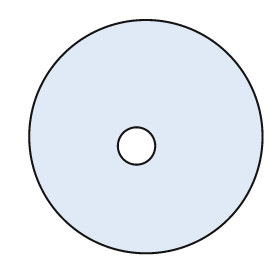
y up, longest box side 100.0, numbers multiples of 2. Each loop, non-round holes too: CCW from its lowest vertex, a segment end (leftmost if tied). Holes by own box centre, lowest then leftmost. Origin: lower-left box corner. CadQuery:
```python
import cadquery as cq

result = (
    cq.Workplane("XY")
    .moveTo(50.0, 50.0)
    .circle(50.0)
    .moveTo(46.0, 46.0)
    .circle(8.0)
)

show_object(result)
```